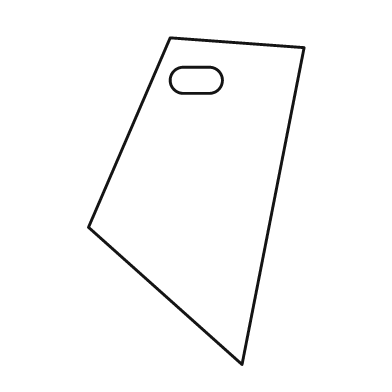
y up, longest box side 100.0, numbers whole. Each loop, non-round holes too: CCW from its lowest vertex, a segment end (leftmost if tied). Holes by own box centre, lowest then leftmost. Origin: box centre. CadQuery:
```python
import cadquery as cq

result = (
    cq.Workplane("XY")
    .moveTo(14.0, -50.0)
    .lineTo(33.0, 47.0)
    .lineTo(-8.0, 50.0)
    .lineTo(-33.0, -8.0)
    .close()
    .moveTo(-4.0, 33.0)
    .lineTo(4.0, 33.0)
    .threePointArc((8.0, 37.0), (4.0, 41.0))
    .lineTo(-4.0, 41.0)
    .threePointArc((-8.0, 37.0), (-4.0, 33.0))
    .close()
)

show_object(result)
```